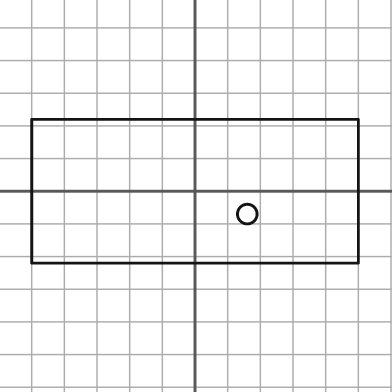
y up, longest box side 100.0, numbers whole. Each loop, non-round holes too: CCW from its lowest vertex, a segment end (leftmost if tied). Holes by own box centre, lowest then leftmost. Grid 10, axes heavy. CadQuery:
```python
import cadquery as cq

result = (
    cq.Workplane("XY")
    .moveTo(-50.0, -22.0)
    .lineTo(50.0, -22.0)
    .lineTo(50.0, 22.0)
    .lineTo(-50.0, 22.0)
    .close()
    .moveTo(16.0, -7.0)
    .circle(3.0)
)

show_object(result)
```